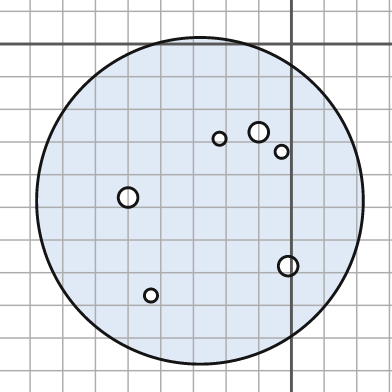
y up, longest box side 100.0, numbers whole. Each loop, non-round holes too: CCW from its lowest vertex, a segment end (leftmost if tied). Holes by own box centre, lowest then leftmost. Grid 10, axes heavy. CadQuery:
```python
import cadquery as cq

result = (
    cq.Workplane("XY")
    .moveTo(-28.0, -48.0)
    .circle(50.0)
    .moveTo(-43.0, -77.0)
    .circle(2.0)
    .moveTo(-1.0, -68.0)
    .circle(3.0)
    .moveTo(-50.0, -47.0)
    .circle(3.0)
    .moveTo(-3.0, -33.0)
    .circle(2.0)
    .moveTo(-22.0, -29.0)
    .circle(2.0)
    .moveTo(-10.0, -27.0)
    .circle(3.0)
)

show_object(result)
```